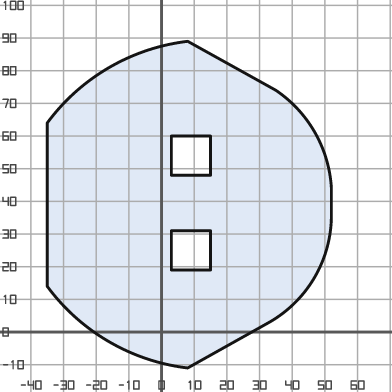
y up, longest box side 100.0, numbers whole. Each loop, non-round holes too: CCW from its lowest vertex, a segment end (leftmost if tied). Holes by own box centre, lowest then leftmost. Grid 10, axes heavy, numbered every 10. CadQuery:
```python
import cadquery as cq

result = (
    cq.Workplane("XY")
    .moveTo(8.0, -11.0)
    .lineTo(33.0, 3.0)
    .threePointArc((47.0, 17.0), (52.0, 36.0))
    .lineTo(52.0, 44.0)
    .threePointArc((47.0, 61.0), (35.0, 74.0))
    .lineTo(8.0, 89.0)
    .threePointArc((-16.0, 81.0), (-35.0, 64.0))
    .lineTo(-35.0, 14.0)
    .threePointArc((-16.0, -3.0), (8.0, -11.0))
    .close()
    .moveTo(3.0, 19.0)
    .lineTo(15.0, 19.0)
    .lineTo(15.0, 31.0)
    .lineTo(3.0, 31.0)
    .close()
    .moveTo(3.0, 48.0)
    .lineTo(15.0, 48.0)
    .lineTo(15.0, 60.0)
    .lineTo(3.0, 60.0)
    .close()
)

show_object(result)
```